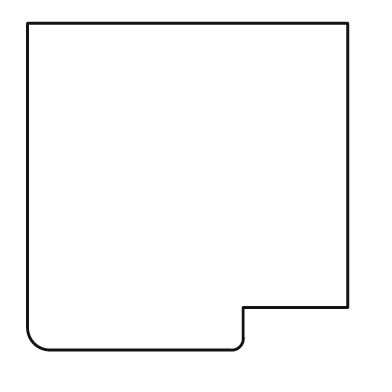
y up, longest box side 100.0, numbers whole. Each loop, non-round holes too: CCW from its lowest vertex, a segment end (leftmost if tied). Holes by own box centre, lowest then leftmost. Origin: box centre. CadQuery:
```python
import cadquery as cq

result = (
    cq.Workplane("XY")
    .moveTo(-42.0, -50.0)
    .lineTo(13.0, -50.0)
    .threePointArc((16.0, -49.0), (17.0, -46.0))
    .lineTo(17.0, -37.0)
    .lineTo(49.0, -37.0)
    .lineTo(49.0, 50.0)
    .lineTo(-49.0, 50.0)
    .lineTo(-49.0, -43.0)
    .threePointArc((-47.0, -48.0), (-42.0, -50.0))
    .close()
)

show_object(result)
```